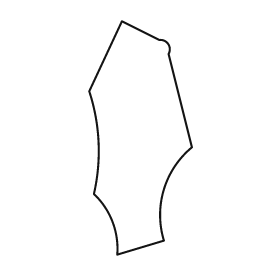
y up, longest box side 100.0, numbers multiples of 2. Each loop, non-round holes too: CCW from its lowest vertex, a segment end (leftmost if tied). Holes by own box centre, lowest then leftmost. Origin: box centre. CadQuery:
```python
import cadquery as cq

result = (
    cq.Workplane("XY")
    .moveTo(-10.0, -50.0)
    .lineTo(10.0, -44.0)
    .threePointArc((10.0, -22.0), (22.0, -4.0))
    .lineTo(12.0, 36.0)
    .threePointArc((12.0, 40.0), (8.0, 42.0))
    .lineTo(-8.0, 50.0)
    .lineTo(-22.0, 20.0)
    .threePointArc((-18.0, -2.0), (-20.0, -24.0))
    .threePointArc((-12.0, -36.0), (-10.0, -50.0))
    .close()
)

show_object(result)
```